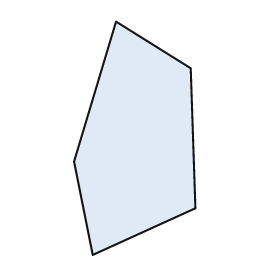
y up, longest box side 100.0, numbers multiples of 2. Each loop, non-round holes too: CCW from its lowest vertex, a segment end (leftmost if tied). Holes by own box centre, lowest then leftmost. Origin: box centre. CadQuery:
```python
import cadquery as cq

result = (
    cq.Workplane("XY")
    .moveTo(-18.0, -50.0)
    .lineTo(26.0, -30.0)
    .lineTo(24.0, 30.0)
    .lineTo(-8.0, 50.0)
    .lineTo(-26.0, -10.0)
    .close()
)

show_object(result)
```